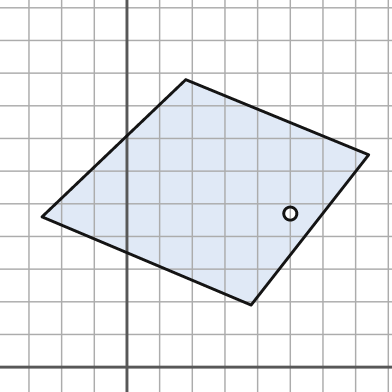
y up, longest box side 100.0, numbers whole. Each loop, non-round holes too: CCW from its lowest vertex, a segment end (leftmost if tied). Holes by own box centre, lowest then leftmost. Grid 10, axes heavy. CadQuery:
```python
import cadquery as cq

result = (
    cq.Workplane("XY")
    .moveTo(38.0, 19.0)
    .lineTo(74.0, 65.0)
    .lineTo(18.0, 88.0)
    .lineTo(-26.0, 46.0)
    .close()
    .moveTo(50.0, 47.0)
    .circle(2.0)
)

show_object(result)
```